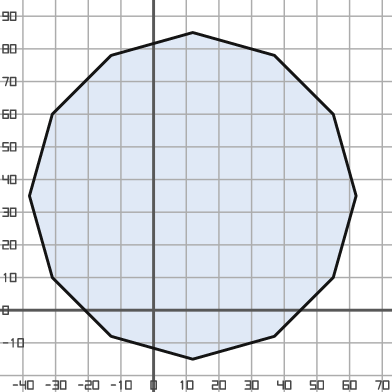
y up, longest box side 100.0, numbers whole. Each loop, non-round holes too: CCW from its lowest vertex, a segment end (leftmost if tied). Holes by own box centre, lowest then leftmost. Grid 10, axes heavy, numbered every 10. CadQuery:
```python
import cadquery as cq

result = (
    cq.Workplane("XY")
    .moveTo(12.0, -15.0)
    .lineTo(37.0, -8.0)
    .lineTo(55.0, 10.0)
    .lineTo(62.0, 35.0)
    .lineTo(55.0, 60.0)
    .lineTo(37.0, 78.0)
    .lineTo(12.0, 85.0)
    .lineTo(-13.0, 78.0)
    .lineTo(-31.0, 60.0)
    .lineTo(-38.0, 35.0)
    .lineTo(-31.0, 10.0)
    .lineTo(-13.0, -8.0)
    .close()
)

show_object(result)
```